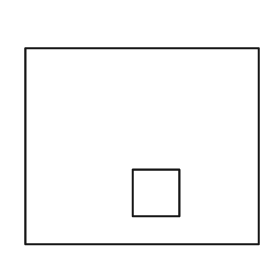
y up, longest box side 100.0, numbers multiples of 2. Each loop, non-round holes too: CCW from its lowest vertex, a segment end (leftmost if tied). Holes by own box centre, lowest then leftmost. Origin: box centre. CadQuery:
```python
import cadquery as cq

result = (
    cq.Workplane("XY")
    .moveTo(-50.0, -42.0)
    .lineTo(50.0, -42.0)
    .lineTo(50.0, 42.0)
    .lineTo(-50.0, 42.0)
    .close()
    .moveTo(-4.0, -30.0)
    .lineTo(16.0, -30.0)
    .lineTo(16.0, -10.0)
    .lineTo(-4.0, -10.0)
    .close()
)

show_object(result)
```